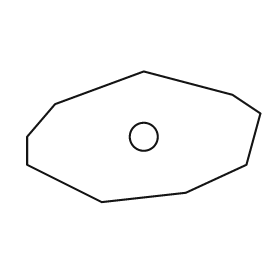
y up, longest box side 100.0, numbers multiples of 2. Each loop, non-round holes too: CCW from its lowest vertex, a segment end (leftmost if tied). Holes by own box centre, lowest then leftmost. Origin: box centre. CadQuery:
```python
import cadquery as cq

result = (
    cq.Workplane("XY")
    .moveTo(-18.0, -28.0)
    .lineTo(18.0, -24.0)
    .lineTo(44.0, -12.0)
    .lineTo(50.0, 10.0)
    .lineTo(38.0, 18.0)
    .lineTo(0.0, 28.0)
    .lineTo(-38.0, 14.0)
    .lineTo(-50.0, 0.0)
    .lineTo(-50.0, -12.0)
    .close()
    .moveTo(0.0, 0.0)
    .circle(6.0)
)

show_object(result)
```